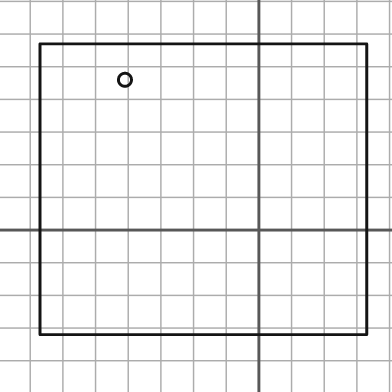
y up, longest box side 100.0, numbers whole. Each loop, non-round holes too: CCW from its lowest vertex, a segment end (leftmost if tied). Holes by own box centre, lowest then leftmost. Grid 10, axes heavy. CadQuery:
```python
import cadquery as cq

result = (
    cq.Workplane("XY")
    .moveTo(-67.0, -32.0)
    .lineTo(33.0, -32.0)
    .lineTo(33.0, 57.0)
    .lineTo(-67.0, 57.0)
    .close()
    .moveTo(-41.0, 46.0)
    .circle(2.0)
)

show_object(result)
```